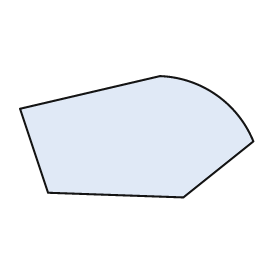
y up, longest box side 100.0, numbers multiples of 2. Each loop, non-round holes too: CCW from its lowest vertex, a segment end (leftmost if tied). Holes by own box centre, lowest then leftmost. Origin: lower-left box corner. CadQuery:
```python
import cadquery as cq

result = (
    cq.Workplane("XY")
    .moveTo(70.0, 0.0)
    .lineTo(100.0, 24.0)
    .threePointArc((84.0, 44.0), (60.0, 52.0))
    .lineTo(0.0, 38.0)
    .lineTo(12.0, 2.0)
    .close()
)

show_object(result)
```